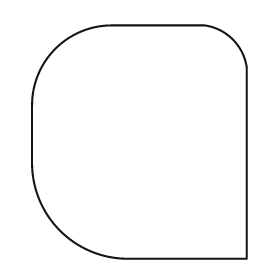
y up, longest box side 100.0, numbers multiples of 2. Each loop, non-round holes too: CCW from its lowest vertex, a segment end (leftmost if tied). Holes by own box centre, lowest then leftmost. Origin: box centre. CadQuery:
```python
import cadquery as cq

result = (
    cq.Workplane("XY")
    .moveTo(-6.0, -50.0)
    .lineTo(46.0, -50.0)
    .lineTo(46.0, 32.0)
    .threePointArc((40.0, 44.0), (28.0, 50.0))
    .lineTo(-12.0, 50.0)
    .threePointArc((-36.0, 40.0), (-46.0, 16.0))
    .lineTo(-46.0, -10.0)
    .threePointArc((-34.0, -38.0), (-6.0, -50.0))
    .close()
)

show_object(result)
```